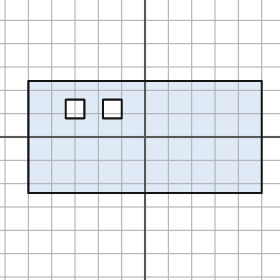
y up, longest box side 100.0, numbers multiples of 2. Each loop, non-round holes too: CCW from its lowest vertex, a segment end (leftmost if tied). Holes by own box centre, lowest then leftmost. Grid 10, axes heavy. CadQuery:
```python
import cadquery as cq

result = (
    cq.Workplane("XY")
    .moveTo(-50.0, -24.0)
    .lineTo(50.0, -24.0)
    .lineTo(50.0, 24.0)
    .lineTo(-50.0, 24.0)
    .close()
    .moveTo(-34.0, 8.0)
    .lineTo(-26.0, 8.0)
    .lineTo(-26.0, 16.0)
    .lineTo(-34.0, 16.0)
    .close()
    .moveTo(-18.0, 8.0)
    .lineTo(-10.0, 8.0)
    .lineTo(-10.0, 16.0)
    .lineTo(-18.0, 16.0)
    .close()
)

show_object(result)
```